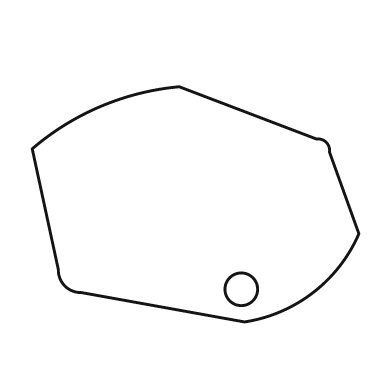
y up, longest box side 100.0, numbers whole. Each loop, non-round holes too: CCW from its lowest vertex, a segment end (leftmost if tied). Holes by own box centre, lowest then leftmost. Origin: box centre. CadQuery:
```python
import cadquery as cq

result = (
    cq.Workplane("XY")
    .moveTo(15.0, -36.0)
    .threePointArc((36.0, -27.0), (50.0, -9.0))
    .lineTo(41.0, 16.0)
    .threePointArc((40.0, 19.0), (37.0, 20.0))
    .lineTo(-5.0, 36.0)
    .threePointArc((-29.0, 30.0), (-50.0, 17.0))
    .lineTo(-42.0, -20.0)
    .threePointArc((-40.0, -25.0), (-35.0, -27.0))
    .close()
    .moveTo(14.0, -26.0)
    .circle(5.0)
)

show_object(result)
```